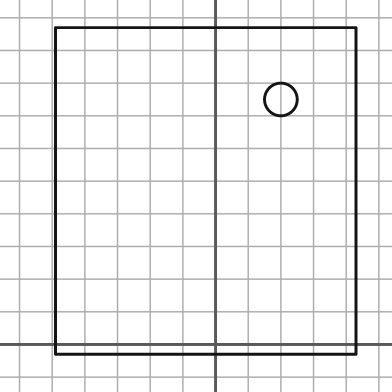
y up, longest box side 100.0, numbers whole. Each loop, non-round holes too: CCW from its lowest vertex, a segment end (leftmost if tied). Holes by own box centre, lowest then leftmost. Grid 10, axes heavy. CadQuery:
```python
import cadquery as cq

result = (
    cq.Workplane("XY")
    .moveTo(-49.0, -3.0)
    .lineTo(43.0, -3.0)
    .lineTo(43.0, 97.0)
    .lineTo(-49.0, 97.0)
    .close()
    .moveTo(20.0, 75.0)
    .circle(5.0)
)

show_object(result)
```